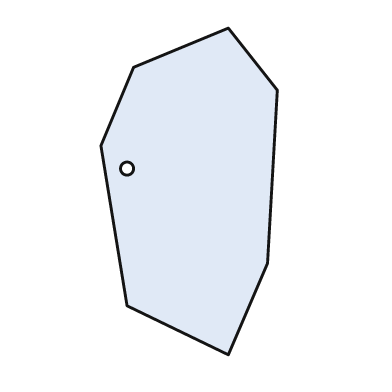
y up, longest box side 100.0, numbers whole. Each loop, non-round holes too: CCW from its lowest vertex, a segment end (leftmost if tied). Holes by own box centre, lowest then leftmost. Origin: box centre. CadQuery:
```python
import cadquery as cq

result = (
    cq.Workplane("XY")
    .moveTo(12.0, -50.0)
    .lineTo(24.0, -22.0)
    .lineTo(27.0, 31.0)
    .lineTo(12.0, 50.0)
    .lineTo(-17.0, 38.0)
    .lineTo(-27.0, 14.0)
    .lineTo(-19.0, -35.0)
    .close()
    .moveTo(-19.0, 7.0)
    .circle(2.0)
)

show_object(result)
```